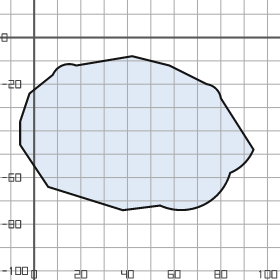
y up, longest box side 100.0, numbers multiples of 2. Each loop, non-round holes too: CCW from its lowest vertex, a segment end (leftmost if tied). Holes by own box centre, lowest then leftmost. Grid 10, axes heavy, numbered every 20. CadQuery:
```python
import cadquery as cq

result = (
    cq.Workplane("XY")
    .moveTo(38.0, -74.0)
    .lineTo(54.0, -72.0)
    .threePointArc((72.0, -72.0), (84.0, -58.0))
    .threePointArc((90.0, -54.0), (94.0, -48.0))
    .lineTo(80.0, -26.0)
    .threePointArc((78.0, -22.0), (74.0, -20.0))
    .lineTo(58.0, -12.0)
    .lineTo(42.0, -8.0)
    .lineTo(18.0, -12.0)
    .threePointArc((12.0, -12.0), (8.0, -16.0))
    .lineTo(-2.0, -24.0)
    .lineTo(-6.0, -36.0)
    .lineTo(-6.0, -46.0)
    .lineTo(6.0, -64.0)
    .close()
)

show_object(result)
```